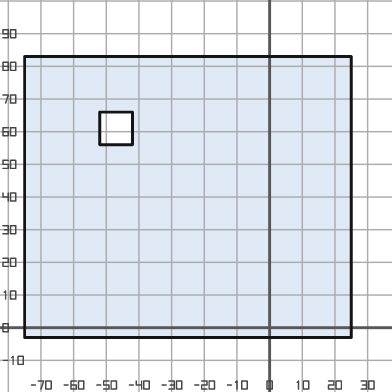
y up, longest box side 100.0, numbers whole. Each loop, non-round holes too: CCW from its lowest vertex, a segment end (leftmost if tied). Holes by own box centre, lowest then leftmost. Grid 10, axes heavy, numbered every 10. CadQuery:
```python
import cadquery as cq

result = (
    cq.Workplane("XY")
    .moveTo(-75.0, -3.0)
    .lineTo(25.0, -3.0)
    .lineTo(25.0, 83.0)
    .lineTo(-75.0, 83.0)
    .close()
    .moveTo(-52.0, 56.0)
    .lineTo(-42.0, 56.0)
    .lineTo(-42.0, 66.0)
    .lineTo(-52.0, 66.0)
    .close()
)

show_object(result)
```